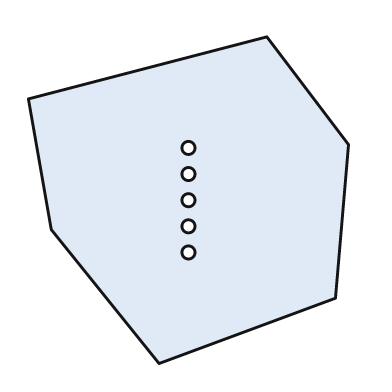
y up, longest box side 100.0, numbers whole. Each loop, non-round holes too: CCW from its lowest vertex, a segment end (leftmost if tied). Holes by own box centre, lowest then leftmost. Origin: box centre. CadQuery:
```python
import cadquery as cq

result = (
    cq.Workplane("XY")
    .moveTo(-9.0, -50.0)
    .lineTo(45.0, -30.0)
    .lineTo(49.0, 17.0)
    .lineTo(24.0, 50.0)
    .lineTo(-49.0, 31.0)
    .lineTo(-42.0, -9.0)
    .close()
    .moveTo(0.0, -16.0)
    .circle(2.0)
    .moveTo(0.0, -8.0)
    .circle(2.0)
    .moveTo(0.0, 0.0)
    .circle(2.0)
    .moveTo(0.0, 8.0)
    .circle(2.0)
    .moveTo(0.0, 16.0)
    .circle(2.0)
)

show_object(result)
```